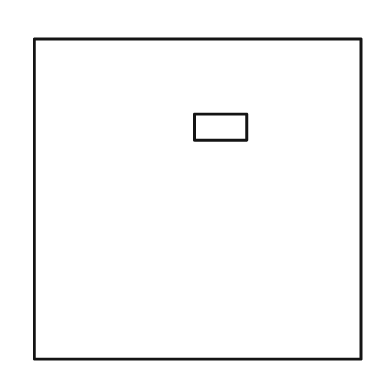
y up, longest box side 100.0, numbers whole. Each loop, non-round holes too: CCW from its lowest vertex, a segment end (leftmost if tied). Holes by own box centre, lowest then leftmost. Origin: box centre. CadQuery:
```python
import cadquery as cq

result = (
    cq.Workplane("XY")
    .moveTo(-50.0, -49.0)
    .lineTo(50.0, -49.0)
    .lineTo(50.0, 49.0)
    .lineTo(-50.0, 49.0)
    .close()
    .moveTo(-1.0, 18.0)
    .lineTo(15.0, 18.0)
    .lineTo(15.0, 26.0)
    .lineTo(-1.0, 26.0)
    .close()
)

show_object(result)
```